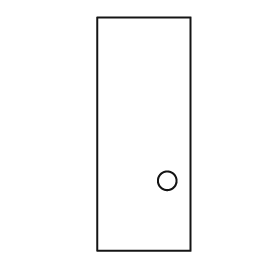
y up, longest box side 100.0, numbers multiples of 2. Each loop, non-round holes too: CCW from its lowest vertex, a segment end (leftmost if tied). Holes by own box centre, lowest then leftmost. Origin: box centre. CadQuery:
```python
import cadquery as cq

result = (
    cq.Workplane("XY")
    .moveTo(-20.0, -50.0)
    .lineTo(20.0, -50.0)
    .lineTo(20.0, 50.0)
    .lineTo(-20.0, 50.0)
    .close()
    .moveTo(10.0, -20.0)
    .circle(4.0)
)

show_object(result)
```